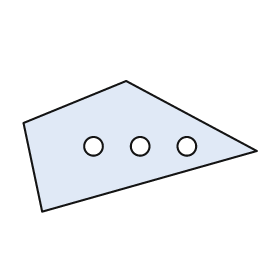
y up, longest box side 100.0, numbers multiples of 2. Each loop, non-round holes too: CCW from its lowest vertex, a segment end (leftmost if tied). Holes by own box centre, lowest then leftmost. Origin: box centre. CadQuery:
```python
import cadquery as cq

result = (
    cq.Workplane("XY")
    .moveTo(-42.0, -28.0)
    .lineTo(50.0, -2.0)
    .lineTo(-6.0, 28.0)
    .lineTo(-50.0, 10.0)
    .close()
    .moveTo(-20.0, 0.0)
    .circle(4.0)
    .moveTo(0.0, 0.0)
    .circle(4.0)
    .moveTo(20.0, 0.0)
    .circle(4.0)
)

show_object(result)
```